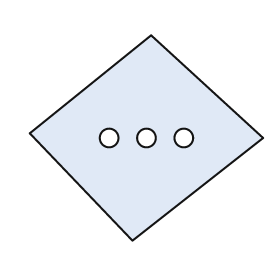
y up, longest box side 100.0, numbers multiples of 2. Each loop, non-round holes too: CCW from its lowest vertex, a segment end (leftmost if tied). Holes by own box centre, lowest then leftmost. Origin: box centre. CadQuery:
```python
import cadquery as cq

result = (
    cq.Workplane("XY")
    .moveTo(-6.0, -44.0)
    .lineTo(50.0, 0.0)
    .lineTo(2.0, 44.0)
    .lineTo(-50.0, 2.0)
    .close()
    .moveTo(-16.0, 0.0)
    .circle(4.0)
    .moveTo(0.0, 0.0)
    .circle(4.0)
    .moveTo(16.0, 0.0)
    .circle(4.0)
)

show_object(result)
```